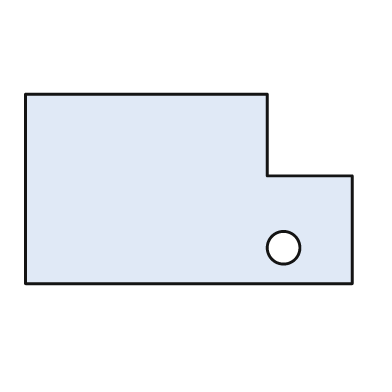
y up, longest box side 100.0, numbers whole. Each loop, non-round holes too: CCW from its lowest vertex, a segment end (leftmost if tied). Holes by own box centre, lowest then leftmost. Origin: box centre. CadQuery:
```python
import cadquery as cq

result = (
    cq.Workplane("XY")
    .moveTo(-50.0, -29.0)
    .lineTo(50.0, -29.0)
    .lineTo(50.0, 4.0)
    .lineTo(24.0, 4.0)
    .lineTo(24.0, 29.0)
    .lineTo(-50.0, 29.0)
    .close()
    .moveTo(29.0, -18.0)
    .circle(5.0)
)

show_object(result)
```